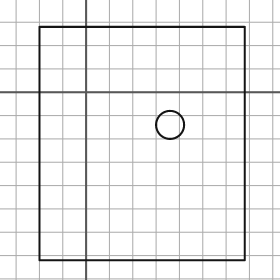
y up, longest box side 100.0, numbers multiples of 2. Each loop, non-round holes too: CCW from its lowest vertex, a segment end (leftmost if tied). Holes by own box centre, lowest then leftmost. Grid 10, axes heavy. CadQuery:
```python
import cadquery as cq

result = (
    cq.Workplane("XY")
    .moveTo(-20.0, -72.0)
    .lineTo(68.0, -72.0)
    .lineTo(68.0, 28.0)
    .lineTo(-20.0, 28.0)
    .close()
    .moveTo(36.0, -14.0)
    .circle(6.0)
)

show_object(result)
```